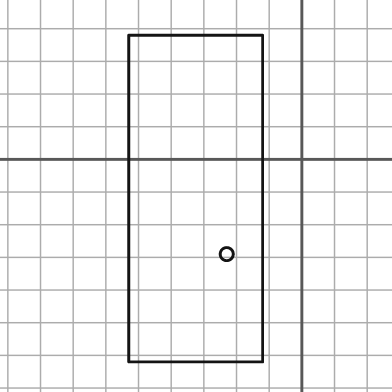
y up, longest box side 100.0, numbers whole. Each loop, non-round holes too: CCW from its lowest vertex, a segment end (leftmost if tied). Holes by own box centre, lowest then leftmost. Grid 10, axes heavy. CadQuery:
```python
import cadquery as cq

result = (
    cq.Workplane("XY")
    .moveTo(-53.0, -62.0)
    .lineTo(-12.0, -62.0)
    .lineTo(-12.0, 38.0)
    .lineTo(-53.0, 38.0)
    .close()
    .moveTo(-23.0, -29.0)
    .circle(2.0)
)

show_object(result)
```